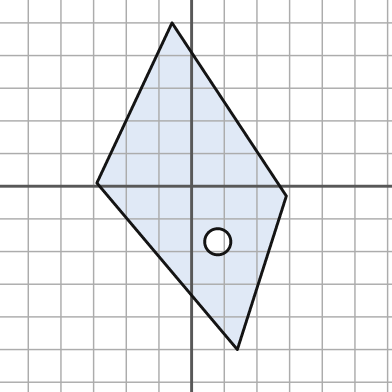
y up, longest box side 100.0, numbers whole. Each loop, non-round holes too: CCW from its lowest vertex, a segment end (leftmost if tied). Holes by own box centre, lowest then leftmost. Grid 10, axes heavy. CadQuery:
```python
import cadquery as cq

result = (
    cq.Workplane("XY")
    .moveTo(14.0, -50.0)
    .lineTo(29.0, -3.0)
    .lineTo(-6.0, 50.0)
    .lineTo(-29.0, 1.0)
    .close()
    .moveTo(8.0, -17.0)
    .circle(4.0)
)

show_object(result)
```